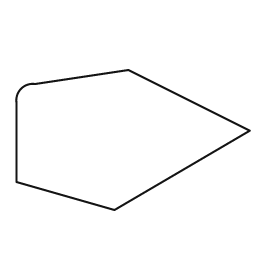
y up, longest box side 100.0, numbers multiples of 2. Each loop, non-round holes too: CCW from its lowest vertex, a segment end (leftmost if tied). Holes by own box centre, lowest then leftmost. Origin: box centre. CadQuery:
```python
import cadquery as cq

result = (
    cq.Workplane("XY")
    .moveTo(-8.0, -30.0)
    .lineTo(50.0, 4.0)
    .lineTo(-2.0, 30.0)
    .lineTo(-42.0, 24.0)
    .threePointArc((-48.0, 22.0), (-50.0, 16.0))
    .lineTo(-50.0, -18.0)
    .close()
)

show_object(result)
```